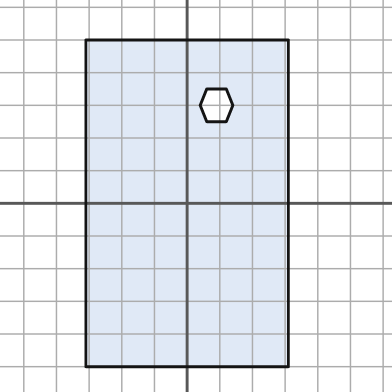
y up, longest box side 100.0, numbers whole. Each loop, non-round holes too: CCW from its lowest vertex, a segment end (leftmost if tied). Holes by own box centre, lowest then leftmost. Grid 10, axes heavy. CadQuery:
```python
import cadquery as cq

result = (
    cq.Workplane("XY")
    .moveTo(-31.0, -50.0)
    .lineTo(31.0, -50.0)
    .lineTo(31.0, 50.0)
    .lineTo(-31.0, 50.0)
    .close()
    .moveTo(6.0, 25.0)
    .lineTo(12.0, 25.0)
    .lineTo(14.0, 30.0)
    .lineTo(12.0, 35.0)
    .lineTo(6.0, 35.0)
    .lineTo(4.0, 30.0)
    .close()
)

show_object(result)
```